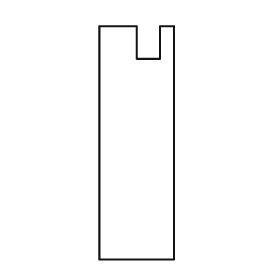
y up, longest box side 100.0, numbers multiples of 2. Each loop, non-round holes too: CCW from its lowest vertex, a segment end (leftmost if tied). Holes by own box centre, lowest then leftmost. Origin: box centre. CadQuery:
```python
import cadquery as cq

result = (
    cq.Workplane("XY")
    .moveTo(-16.0, -50.0)
    .lineTo(16.0, -50.0)
    .lineTo(16.0, 50.0)
    .lineTo(10.0, 50.0)
    .lineTo(10.0, 36.0)
    .lineTo(0.0, 36.0)
    .lineTo(0.0, 50.0)
    .lineTo(-16.0, 50.0)
    .close()
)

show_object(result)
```